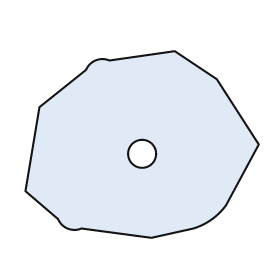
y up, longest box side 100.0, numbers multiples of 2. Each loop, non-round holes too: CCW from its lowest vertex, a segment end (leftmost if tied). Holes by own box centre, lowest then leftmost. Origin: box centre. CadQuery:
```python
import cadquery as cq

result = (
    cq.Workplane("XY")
    .moveTo(4.0, -40.0)
    .lineTo(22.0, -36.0)
    .threePointArc((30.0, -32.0), (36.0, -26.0))
    .lineTo(50.0, 0.0)
    .lineTo(32.0, 28.0)
    .lineTo(14.0, 40.0)
    .lineTo(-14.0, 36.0)
    .threePointArc((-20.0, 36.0), (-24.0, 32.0))
    .lineTo(-44.0, 16.0)
    .lineTo(-50.0, -20.0)
    .lineTo(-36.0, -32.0)
    .threePointArc((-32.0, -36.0), (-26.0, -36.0))
    .close()
    .moveTo(0.0, -4.0)
    .circle(6.0)
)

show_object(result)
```